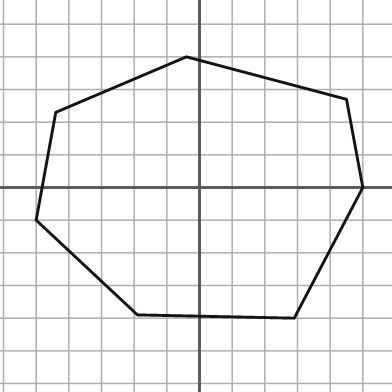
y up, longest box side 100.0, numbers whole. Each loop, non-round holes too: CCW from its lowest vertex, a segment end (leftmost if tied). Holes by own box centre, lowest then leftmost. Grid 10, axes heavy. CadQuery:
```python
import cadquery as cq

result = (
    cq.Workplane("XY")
    .moveTo(29.0, -40.0)
    .lineTo(50.0, 0.0)
    .lineTo(45.0, 27.0)
    .lineTo(-4.0, 40.0)
    .lineTo(-44.0, 23.0)
    .lineTo(-50.0, -10.0)
    .lineTo(-19.0, -39.0)
    .close()
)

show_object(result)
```